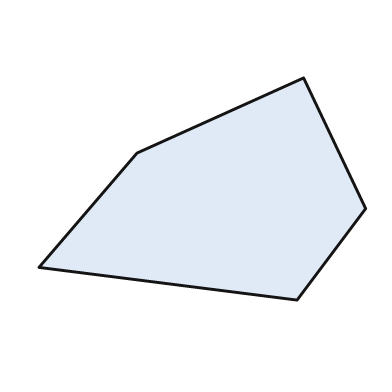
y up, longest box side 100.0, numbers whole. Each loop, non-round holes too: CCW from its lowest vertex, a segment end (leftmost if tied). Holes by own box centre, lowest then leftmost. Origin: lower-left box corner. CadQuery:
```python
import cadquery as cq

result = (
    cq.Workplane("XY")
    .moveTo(79.0, 0.0)
    .lineTo(100.0, 28.0)
    .lineTo(81.0, 68.0)
    .lineTo(30.0, 45.0)
    .lineTo(0.0, 10.0)
    .close()
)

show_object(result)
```